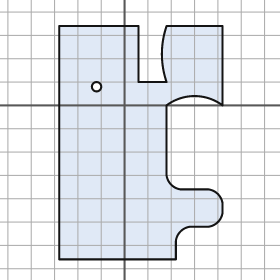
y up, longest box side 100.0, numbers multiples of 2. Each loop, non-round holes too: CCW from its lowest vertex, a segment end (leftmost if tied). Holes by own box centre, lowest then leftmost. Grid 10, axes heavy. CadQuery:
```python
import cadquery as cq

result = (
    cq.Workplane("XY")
    .moveTo(-28.0, -66.0)
    .lineTo(22.0, -66.0)
    .lineTo(22.0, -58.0)
    .threePointArc((24.0, -54.0), (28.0, -52.0))
    .lineTo(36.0, -52.0)
    .threePointArc((40.0, -50.0), (42.0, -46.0))
    .lineTo(42.0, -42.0)
    .threePointArc((40.0, -38.0), (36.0, -36.0))
    .lineTo(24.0, -36.0)
    .threePointArc((20.0, -34.0), (18.0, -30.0))
    .lineTo(18.0, 0.0)
    .threePointArc((30.0, 4.0), (42.0, 0.0))
    .lineTo(42.0, 34.0)
    .lineTo(18.0, 34.0)
    .threePointArc((16.0, 22.0), (18.0, 10.0))
    .lineTo(6.0, 10.0)
    .lineTo(6.0, 34.0)
    .lineTo(-28.0, 34.0)
    .close()
    .moveTo(-12.0, 8.0)
    .circle(2.0)
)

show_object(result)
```